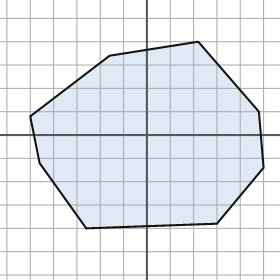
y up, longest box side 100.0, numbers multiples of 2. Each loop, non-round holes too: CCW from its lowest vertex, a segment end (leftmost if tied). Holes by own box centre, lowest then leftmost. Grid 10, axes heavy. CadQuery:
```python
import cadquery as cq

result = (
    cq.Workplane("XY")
    .moveTo(-26.0, -40.0)
    .lineTo(30.0, -38.0)
    .lineTo(50.0, -14.0)
    .lineTo(48.0, 10.0)
    .lineTo(22.0, 40.0)
    .lineTo(-16.0, 34.0)
    .lineTo(-50.0, 8.0)
    .lineTo(-46.0, -12.0)
    .close()
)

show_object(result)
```